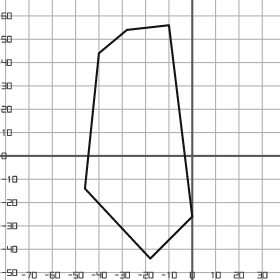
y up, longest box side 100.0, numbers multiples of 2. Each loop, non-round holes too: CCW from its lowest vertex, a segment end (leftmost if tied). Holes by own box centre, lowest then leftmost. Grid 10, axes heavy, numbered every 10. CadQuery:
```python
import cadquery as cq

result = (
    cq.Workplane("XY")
    .moveTo(-18.0, -44.0)
    .lineTo(0.0, -26.0)
    .lineTo(-10.0, 56.0)
    .lineTo(-28.0, 54.0)
    .lineTo(-40.0, 44.0)
    .lineTo(-46.0, -14.0)
    .close()
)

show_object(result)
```